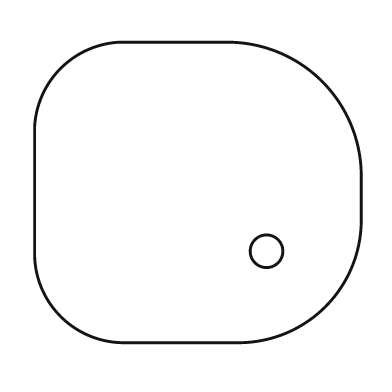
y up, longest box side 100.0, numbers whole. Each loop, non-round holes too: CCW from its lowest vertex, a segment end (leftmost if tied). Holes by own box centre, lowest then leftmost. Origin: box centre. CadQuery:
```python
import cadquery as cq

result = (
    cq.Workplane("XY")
    .moveTo(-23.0, -46.0)
    .lineTo(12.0, -46.0)
    .threePointArc((39.0, -35.0), (50.0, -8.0))
    .lineTo(50.0, 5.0)
    .threePointArc((38.0, 34.0), (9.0, 46.0))
    .lineTo(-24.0, 46.0)
    .threePointArc((-42.0, 38.0), (-50.0, 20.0))
    .lineTo(-50.0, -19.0)
    .threePointArc((-42.0, -38.0), (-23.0, -46.0))
    .close()
    .moveTo(21.0, -18.0)
    .circle(5.0)
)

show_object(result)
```